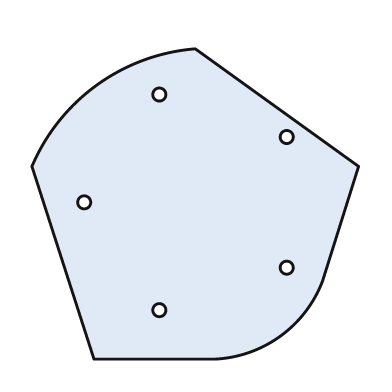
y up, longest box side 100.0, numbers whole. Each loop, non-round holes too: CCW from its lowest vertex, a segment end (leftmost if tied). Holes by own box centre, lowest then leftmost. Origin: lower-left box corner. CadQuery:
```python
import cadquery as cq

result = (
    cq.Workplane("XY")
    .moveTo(19.0, 0.0)
    .lineTo(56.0, 0.0)
    .threePointArc((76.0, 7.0), (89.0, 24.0))
    .lineTo(100.0, 59.0)
    .lineTo(50.0, 95.0)
    .threePointArc((20.0, 84.0), (0.0, 59.0))
    .close()
    .moveTo(39.0, 15.0)
    .circle(2.0)
    .moveTo(78.0, 28.0)
    .circle(2.0)
    .moveTo(16.0, 48.0)
    .circle(2.0)
    .moveTo(78.0, 68.0)
    .circle(2.0)
    .moveTo(39.0, 81.0)
    .circle(2.0)
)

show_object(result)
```